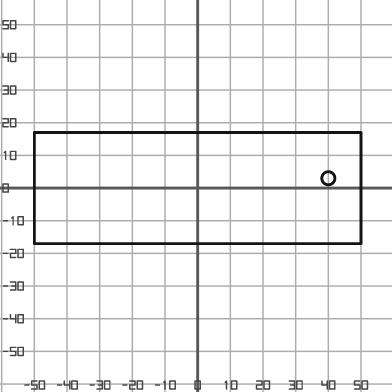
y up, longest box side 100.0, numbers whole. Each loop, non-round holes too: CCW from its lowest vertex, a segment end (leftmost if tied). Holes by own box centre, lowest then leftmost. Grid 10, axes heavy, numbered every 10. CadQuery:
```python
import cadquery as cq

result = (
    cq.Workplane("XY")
    .moveTo(-50.0, -17.0)
    .lineTo(50.0, -17.0)
    .lineTo(50.0, 17.0)
    .lineTo(-50.0, 17.0)
    .close()
    .moveTo(40.0, 3.0)
    .circle(2.0)
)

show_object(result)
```